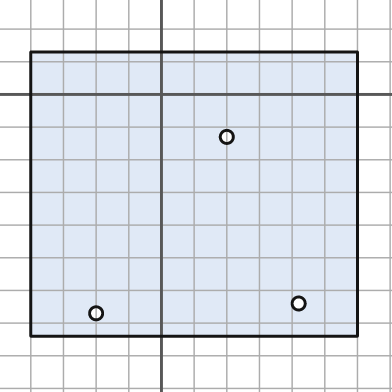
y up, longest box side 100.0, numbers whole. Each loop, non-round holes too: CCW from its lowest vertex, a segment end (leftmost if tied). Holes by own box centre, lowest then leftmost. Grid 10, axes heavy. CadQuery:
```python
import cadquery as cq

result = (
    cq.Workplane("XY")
    .moveTo(-40.0, -74.0)
    .lineTo(60.0, -74.0)
    .lineTo(60.0, 13.0)
    .lineTo(-40.0, 13.0)
    .close()
    .moveTo(-20.0, -67.0)
    .circle(2.0)
    .moveTo(42.0, -64.0)
    .circle(2.0)
    .moveTo(20.0, -13.0)
    .circle(2.0)
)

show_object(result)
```